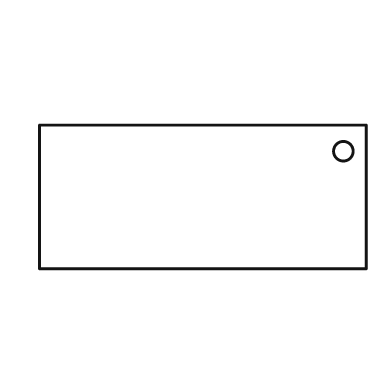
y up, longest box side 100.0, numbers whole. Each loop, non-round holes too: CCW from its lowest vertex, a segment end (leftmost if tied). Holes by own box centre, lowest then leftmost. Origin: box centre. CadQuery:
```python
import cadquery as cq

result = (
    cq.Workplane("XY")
    .moveTo(-50.0, -22.0)
    .lineTo(50.0, -22.0)
    .lineTo(50.0, 22.0)
    .lineTo(-50.0, 22.0)
    .close()
    .moveTo(43.0, 14.0)
    .circle(3.0)
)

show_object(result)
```